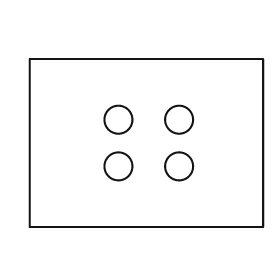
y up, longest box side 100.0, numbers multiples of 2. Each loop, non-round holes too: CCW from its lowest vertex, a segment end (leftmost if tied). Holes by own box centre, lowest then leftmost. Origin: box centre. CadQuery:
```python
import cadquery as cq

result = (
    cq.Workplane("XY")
    .moveTo(-50.0, -36.0)
    .lineTo(50.0, -36.0)
    .lineTo(50.0, 36.0)
    .lineTo(-50.0, 36.0)
    .close()
    .moveTo(-12.0, -10.0)
    .circle(6.0)
    .moveTo(14.0, -10.0)
    .circle(6.0)
    .moveTo(-12.0, 10.0)
    .circle(6.0)
    .moveTo(14.0, 10.0)
    .circle(6.0)
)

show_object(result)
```